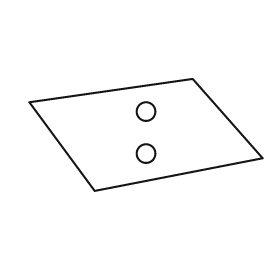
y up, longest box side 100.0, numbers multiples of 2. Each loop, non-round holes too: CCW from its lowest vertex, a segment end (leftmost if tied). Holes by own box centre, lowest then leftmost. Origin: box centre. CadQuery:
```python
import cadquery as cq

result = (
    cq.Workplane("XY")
    .moveTo(-22.0, -24.0)
    .lineTo(50.0, -10.0)
    .lineTo(20.0, 24.0)
    .lineTo(-50.0, 14.0)
    .close()
    .moveTo(0.0, -8.0)
    .circle(4.0)
    .moveTo(0.0, 10.0)
    .circle(4.0)
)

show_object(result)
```